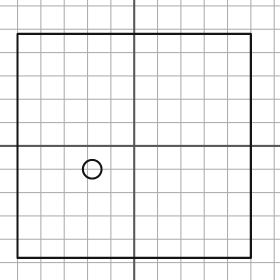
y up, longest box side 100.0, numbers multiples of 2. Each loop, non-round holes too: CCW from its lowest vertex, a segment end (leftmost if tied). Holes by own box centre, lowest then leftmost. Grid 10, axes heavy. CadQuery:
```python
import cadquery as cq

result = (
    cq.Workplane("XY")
    .moveTo(-50.0, -48.0)
    .lineTo(50.0, -48.0)
    .lineTo(50.0, 48.0)
    .lineTo(-50.0, 48.0)
    .close()
    .moveTo(-18.0, -10.0)
    .circle(4.0)
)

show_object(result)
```